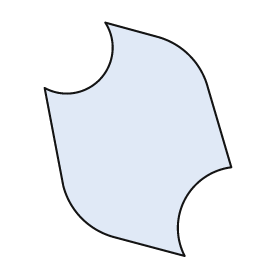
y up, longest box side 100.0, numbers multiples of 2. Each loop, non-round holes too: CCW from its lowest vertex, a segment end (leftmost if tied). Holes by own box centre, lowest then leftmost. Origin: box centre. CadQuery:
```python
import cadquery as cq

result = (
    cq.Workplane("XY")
    .moveTo(20.0, -50.0)
    .threePointArc((20.0, -26.0), (40.0, -12.0))
    .lineTo(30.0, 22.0)
    .threePointArc((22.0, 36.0), (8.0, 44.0))
    .lineTo(-14.0, 50.0)
    .threePointArc((-16.0, 26.0), (-40.0, 22.0))
    .lineTo(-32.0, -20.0)
    .threePointArc((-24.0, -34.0), (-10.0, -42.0))
    .close()
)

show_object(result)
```